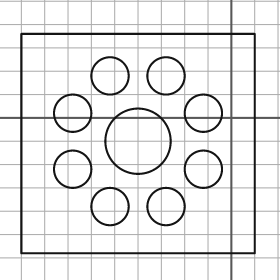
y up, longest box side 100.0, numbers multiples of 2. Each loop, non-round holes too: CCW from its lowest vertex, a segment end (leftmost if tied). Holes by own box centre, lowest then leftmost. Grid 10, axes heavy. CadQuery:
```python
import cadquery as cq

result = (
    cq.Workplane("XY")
    .moveTo(-90.0, -58.0)
    .lineTo(10.0, -58.0)
    .lineTo(10.0, 36.0)
    .lineTo(-90.0, 36.0)
    .close()
    .moveTo(-52.0, -38.0)
    .circle(8.0)
    .moveTo(-28.0, -38.0)
    .circle(8.0)
    .moveTo(-68.0, -22.0)
    .circle(8.0)
    .moveTo(-12.0, -22.0)
    .circle(8.0)
    .moveTo(-40.0, -10.0)
    .circle(14.0)
    .moveTo(-68.0, 2.0)
    .circle(8.0)
    .moveTo(-12.0, 2.0)
    .circle(8.0)
    .moveTo(-52.0, 18.0)
    .circle(8.0)
    .moveTo(-28.0, 18.0)
    .circle(8.0)
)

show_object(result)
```